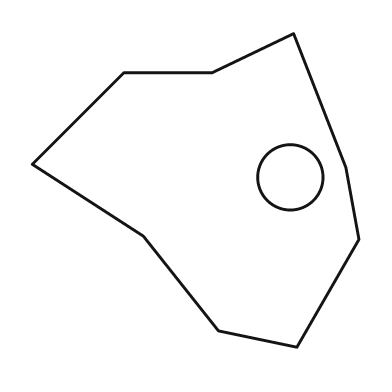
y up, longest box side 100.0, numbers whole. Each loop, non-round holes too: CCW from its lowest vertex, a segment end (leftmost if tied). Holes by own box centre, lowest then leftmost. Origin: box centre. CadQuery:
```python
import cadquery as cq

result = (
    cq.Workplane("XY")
    .moveTo(31.0, -48.0)
    .lineTo(50.0, -15.0)
    .lineTo(46.0, 7.0)
    .lineTo(30.0, 48.0)
    .lineTo(5.0, 36.0)
    .lineTo(-22.0, 36.0)
    .lineTo(-50.0, 8.0)
    .lineTo(-16.0, -14.0)
    .lineTo(7.0, -43.0)
    .close()
    .moveTo(29.0, 4.0)
    .circle(10.0)
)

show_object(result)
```